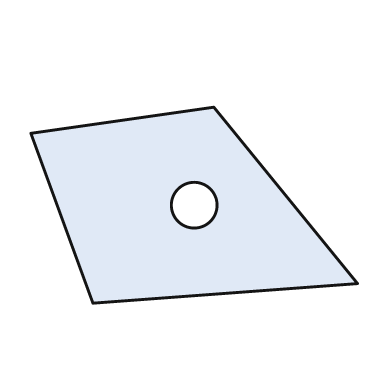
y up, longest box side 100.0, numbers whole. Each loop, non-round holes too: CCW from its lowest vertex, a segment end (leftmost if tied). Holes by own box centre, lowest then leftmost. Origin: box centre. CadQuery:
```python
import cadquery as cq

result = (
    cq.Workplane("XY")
    .moveTo(-31.0, -30.0)
    .lineTo(50.0, -24.0)
    .lineTo(6.0, 30.0)
    .lineTo(-50.0, 22.0)
    .close()
    .moveTo(0.0, 0.0)
    .circle(7.0)
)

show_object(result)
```